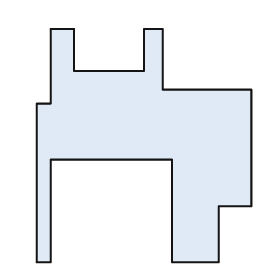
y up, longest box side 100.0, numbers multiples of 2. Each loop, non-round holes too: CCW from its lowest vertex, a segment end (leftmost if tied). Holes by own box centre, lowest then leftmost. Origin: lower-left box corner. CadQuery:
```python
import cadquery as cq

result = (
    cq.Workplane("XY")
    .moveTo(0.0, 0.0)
    .lineTo(6.0, 0.0)
    .lineTo(6.0, 44.0)
    .lineTo(58.0, 44.0)
    .lineTo(58.0, 0.0)
    .lineTo(78.0, 0.0)
    .lineTo(78.0, 24.0)
    .lineTo(92.0, 24.0)
    .lineTo(92.0, 74.0)
    .lineTo(54.0, 74.0)
    .lineTo(54.0, 100.0)
    .lineTo(46.0, 100.0)
    .lineTo(46.0, 82.0)
    .lineTo(16.0, 82.0)
    .lineTo(16.0, 100.0)
    .lineTo(6.0, 100.0)
    .lineTo(6.0, 68.0)
    .lineTo(0.0, 68.0)
    .close()
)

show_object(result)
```